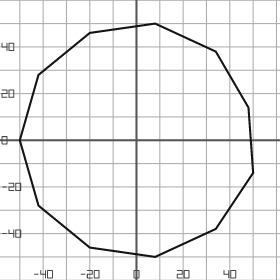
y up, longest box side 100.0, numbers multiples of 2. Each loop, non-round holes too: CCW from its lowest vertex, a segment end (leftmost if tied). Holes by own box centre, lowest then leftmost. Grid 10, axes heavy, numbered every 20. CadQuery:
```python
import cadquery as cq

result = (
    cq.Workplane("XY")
    .moveTo(8.0, -50.0)
    .lineTo(34.0, -38.0)
    .lineTo(50.0, -14.0)
    .lineTo(48.0, 14.0)
    .lineTo(34.0, 38.0)
    .lineTo(8.0, 50.0)
    .lineTo(-20.0, 46.0)
    .lineTo(-42.0, 28.0)
    .lineTo(-50.0, 0.0)
    .lineTo(-42.0, -28.0)
    .lineTo(-20.0, -46.0)
    .close()
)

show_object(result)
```